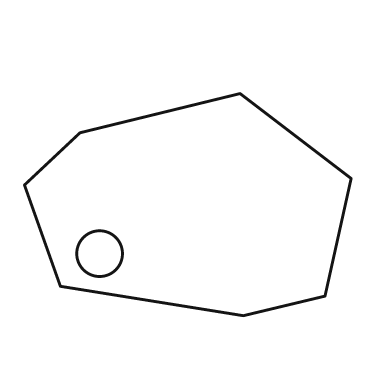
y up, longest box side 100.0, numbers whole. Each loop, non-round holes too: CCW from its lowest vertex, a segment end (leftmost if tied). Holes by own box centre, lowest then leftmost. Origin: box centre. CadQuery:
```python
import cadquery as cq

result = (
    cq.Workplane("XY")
    .moveTo(17.0, -34.0)
    .lineTo(42.0, -28.0)
    .lineTo(50.0, 8.0)
    .lineTo(16.0, 34.0)
    .lineTo(-33.0, 22.0)
    .lineTo(-50.0, 6.0)
    .lineTo(-39.0, -25.0)
    .close()
    .moveTo(-27.0, -15.0)
    .circle(7.0)
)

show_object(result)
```